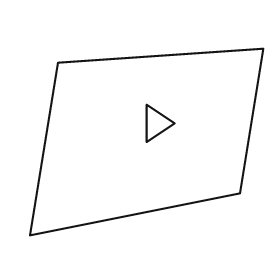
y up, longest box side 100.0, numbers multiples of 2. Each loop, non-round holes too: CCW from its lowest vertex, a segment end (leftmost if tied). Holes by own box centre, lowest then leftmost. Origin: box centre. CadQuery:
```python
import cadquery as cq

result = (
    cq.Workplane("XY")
    .moveTo(-50.0, -40.0)
    .lineTo(40.0, -22.0)
    .lineTo(50.0, 40.0)
    .lineTo(-38.0, 34.0)
    .close()
    .moveTo(0.0, 0.0)
    .lineTo(12.0, 8.0)
    .lineTo(0.0, 16.0)
    .close()
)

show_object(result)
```